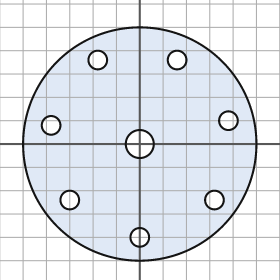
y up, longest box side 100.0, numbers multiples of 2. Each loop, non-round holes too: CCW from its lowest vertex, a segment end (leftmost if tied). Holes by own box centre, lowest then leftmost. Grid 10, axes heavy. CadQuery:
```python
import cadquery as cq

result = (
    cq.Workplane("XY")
    .moveTo(0.0, 0.0)
    .circle(50.0)
    .moveTo(0.0, -40.0)
    .circle(4.0)
    .moveTo(-30.0, -24.0)
    .circle(4.0)
    .moveTo(32.0, -24.0)
    .circle(4.0)
    .moveTo(0.0, 0.0)
    .circle(6.0)
    .moveTo(-38.0, 8.0)
    .circle(4.0)
    .moveTo(38.0, 10.0)
    .circle(4.0)
    .moveTo(-18.0, 36.0)
    .circle(4.0)
    .moveTo(16.0, 36.0)
    .circle(4.0)
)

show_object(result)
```